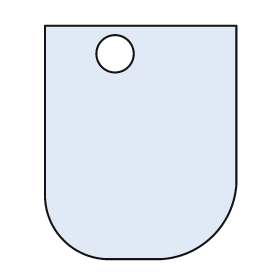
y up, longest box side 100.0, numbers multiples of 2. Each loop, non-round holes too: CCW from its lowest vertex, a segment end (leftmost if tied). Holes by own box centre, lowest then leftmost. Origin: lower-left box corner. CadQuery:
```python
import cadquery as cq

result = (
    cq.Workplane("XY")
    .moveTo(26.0, 0.0)
    .lineTo(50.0, 0.0)
    .threePointArc((72.0, 10.0), (82.0, 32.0))
    .lineTo(82.0, 100.0)
    .lineTo(0.0, 100.0)
    .lineTo(0.0, 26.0)
    .threePointArc((8.0, 8.0), (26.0, 0.0))
    .close()
    .moveTo(30.0, 88.0)
    .circle(8.0)
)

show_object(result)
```